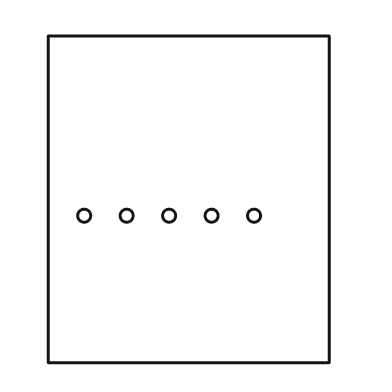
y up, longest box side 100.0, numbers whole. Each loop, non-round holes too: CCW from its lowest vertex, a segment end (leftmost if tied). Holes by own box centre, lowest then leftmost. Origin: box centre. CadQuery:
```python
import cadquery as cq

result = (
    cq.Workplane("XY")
    .moveTo(-43.0, -50.0)
    .lineTo(43.0, -50.0)
    .lineTo(43.0, 50.0)
    .lineTo(-43.0, 50.0)
    .close()
    .moveTo(-32.0, -5.0)
    .circle(2.0)
    .moveTo(-19.0, -5.0)
    .circle(2.0)
    .moveTo(-6.0, -5.0)
    .circle(2.0)
    .moveTo(7.0, -5.0)
    .circle(2.0)
    .moveTo(20.0, -5.0)
    .circle(2.0)
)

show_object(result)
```